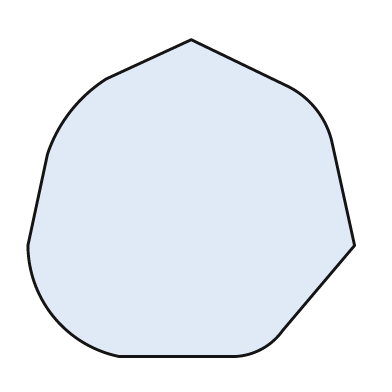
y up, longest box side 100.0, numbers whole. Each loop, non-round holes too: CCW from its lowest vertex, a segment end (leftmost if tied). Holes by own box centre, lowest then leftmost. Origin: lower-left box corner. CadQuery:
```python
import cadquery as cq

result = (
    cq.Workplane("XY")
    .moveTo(28.0, 0.0)
    .lineTo(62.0, 0.0)
    .threePointArc((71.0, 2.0), (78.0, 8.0))
    .lineTo(100.0, 34.0)
    .lineTo(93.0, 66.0)
    .threePointArc((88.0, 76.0), (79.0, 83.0))
    .lineTo(50.0, 97.0)
    .lineTo(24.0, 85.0)
    .threePointArc((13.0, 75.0), (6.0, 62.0))
    .lineTo(0.0, 34.0)
    .threePointArc((8.0, 12.0), (28.0, 0.0))
    .close()
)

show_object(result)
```